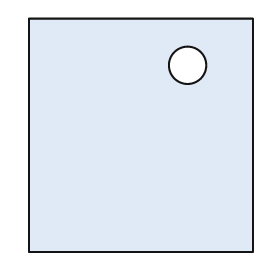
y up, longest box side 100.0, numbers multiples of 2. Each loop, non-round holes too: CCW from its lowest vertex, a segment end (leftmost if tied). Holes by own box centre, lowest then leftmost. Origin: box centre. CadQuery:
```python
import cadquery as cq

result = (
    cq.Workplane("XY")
    .moveTo(-48.0, -50.0)
    .lineTo(48.0, -50.0)
    .lineTo(48.0, 50.0)
    .lineTo(-48.0, 50.0)
    .close()
    .moveTo(20.0, 30.0)
    .circle(8.0)
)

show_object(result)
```